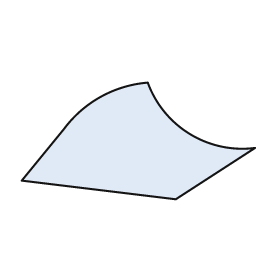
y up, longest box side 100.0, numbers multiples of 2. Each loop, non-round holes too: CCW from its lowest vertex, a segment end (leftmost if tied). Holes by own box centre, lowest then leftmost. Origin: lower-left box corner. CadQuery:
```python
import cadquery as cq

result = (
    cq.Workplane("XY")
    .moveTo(66.0, 0.0)
    .lineTo(100.0, 22.0)
    .threePointArc((72.0, 28.0), (54.0, 50.0))
    .threePointArc((34.0, 44.0), (18.0, 30.0))
    .lineTo(0.0, 8.0)
    .close()
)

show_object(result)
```